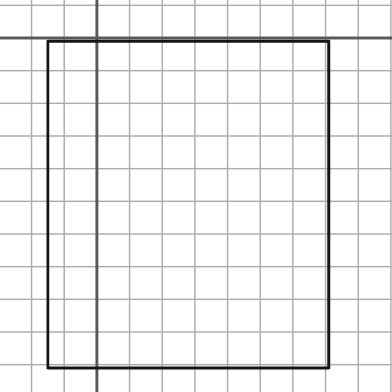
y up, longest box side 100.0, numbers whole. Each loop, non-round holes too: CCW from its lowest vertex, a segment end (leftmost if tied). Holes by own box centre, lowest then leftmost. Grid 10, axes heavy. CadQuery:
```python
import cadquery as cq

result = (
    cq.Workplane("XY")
    .moveTo(-15.0, -101.0)
    .lineTo(71.0, -101.0)
    .lineTo(71.0, -1.0)
    .lineTo(-15.0, -1.0)
    .close()
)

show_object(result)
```